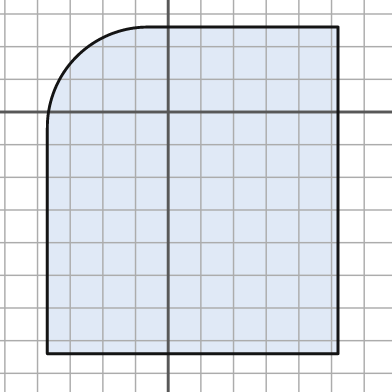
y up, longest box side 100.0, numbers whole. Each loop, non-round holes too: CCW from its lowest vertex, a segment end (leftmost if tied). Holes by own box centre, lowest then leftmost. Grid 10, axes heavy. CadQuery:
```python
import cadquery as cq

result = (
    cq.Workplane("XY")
    .moveTo(-37.0, -74.0)
    .lineTo(52.0, -74.0)
    .lineTo(52.0, 26.0)
    .lineTo(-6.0, 26.0)
    .threePointArc((-28.0, 17.0), (-37.0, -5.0))
    .close()
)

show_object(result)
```